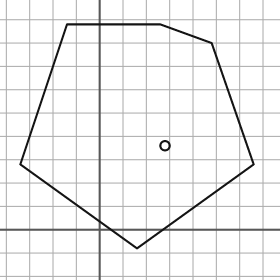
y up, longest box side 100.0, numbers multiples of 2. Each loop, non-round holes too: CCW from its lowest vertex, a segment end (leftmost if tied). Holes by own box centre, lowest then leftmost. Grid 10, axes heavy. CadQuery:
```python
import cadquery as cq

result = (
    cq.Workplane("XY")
    .moveTo(16.0, -8.0)
    .lineTo(66.0, 28.0)
    .lineTo(48.0, 80.0)
    .lineTo(26.0, 88.0)
    .lineTo(-14.0, 88.0)
    .lineTo(-34.0, 28.0)
    .close()
    .moveTo(28.0, 36.0)
    .circle(2.0)
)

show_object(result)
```